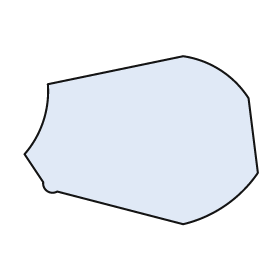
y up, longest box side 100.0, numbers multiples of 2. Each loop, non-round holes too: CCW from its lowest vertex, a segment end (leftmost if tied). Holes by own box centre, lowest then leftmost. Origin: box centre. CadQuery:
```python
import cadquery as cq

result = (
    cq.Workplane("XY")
    .moveTo(18.0, -36.0)
    .threePointArc((36.0, -28.0), (50.0, -14.0))
    .lineTo(46.0, 18.0)
    .threePointArc((34.0, 30.0), (18.0, 36.0))
    .lineTo(-40.0, 24.0)
    .threePointArc((-42.0, 8.0), (-50.0, -6.0))
    .lineTo(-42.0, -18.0)
    .threePointArc((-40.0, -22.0), (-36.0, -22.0))
    .close()
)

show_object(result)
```